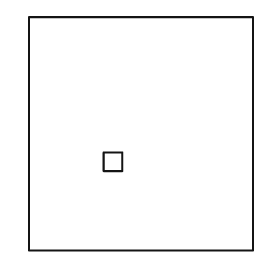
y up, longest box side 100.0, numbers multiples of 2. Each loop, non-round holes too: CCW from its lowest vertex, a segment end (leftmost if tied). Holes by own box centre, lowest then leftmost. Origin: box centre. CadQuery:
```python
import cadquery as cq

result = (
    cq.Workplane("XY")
    .moveTo(-48.0, -50.0)
    .lineTo(48.0, -50.0)
    .lineTo(48.0, 50.0)
    .lineTo(-48.0, 50.0)
    .close()
    .moveTo(-16.0, -16.0)
    .lineTo(-8.0, -16.0)
    .lineTo(-8.0, -8.0)
    .lineTo(-16.0, -8.0)
    .close()
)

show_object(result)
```